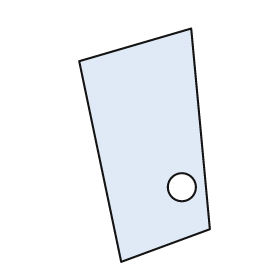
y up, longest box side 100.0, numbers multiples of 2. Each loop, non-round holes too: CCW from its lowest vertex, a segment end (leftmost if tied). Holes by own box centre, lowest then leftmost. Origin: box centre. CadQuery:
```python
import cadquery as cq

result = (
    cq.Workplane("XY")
    .moveTo(-10.0, -50.0)
    .lineTo(28.0, -36.0)
    .lineTo(20.0, 50.0)
    .lineTo(-28.0, 36.0)
    .close()
    .moveTo(16.0, -18.0)
    .circle(6.0)
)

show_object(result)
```